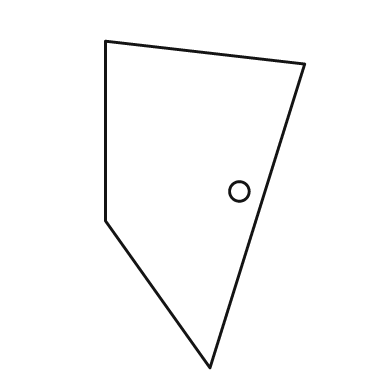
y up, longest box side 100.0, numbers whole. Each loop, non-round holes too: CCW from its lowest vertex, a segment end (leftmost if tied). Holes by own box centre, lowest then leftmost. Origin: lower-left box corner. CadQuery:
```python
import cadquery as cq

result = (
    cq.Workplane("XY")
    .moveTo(32.0, 0.0)
    .lineTo(61.0, 93.0)
    .lineTo(0.0, 100.0)
    .lineTo(0.0, 45.0)
    .close()
    .moveTo(41.0, 54.0)
    .circle(3.0)
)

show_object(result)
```